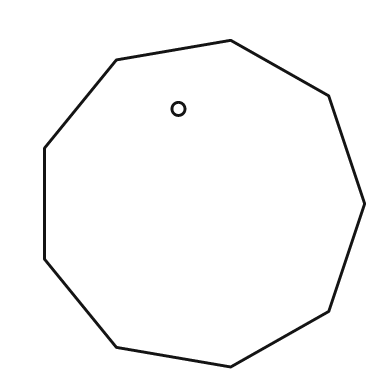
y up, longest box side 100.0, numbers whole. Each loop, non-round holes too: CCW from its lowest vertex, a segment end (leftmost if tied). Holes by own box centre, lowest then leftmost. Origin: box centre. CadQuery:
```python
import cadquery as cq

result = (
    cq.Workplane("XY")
    .moveTo(8.0, -50.0)
    .lineTo(38.0, -33.0)
    .lineTo(49.0, 0.0)
    .lineTo(38.0, 33.0)
    .lineTo(8.0, 50.0)
    .lineTo(-27.0, 44.0)
    .lineTo(-49.0, 17.0)
    .lineTo(-49.0, -17.0)
    .lineTo(-27.0, -44.0)
    .close()
    .moveTo(-8.0, 29.0)
    .circle(2.0)
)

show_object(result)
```